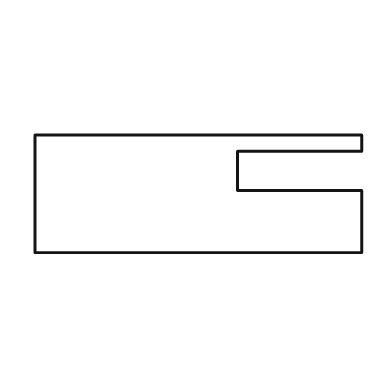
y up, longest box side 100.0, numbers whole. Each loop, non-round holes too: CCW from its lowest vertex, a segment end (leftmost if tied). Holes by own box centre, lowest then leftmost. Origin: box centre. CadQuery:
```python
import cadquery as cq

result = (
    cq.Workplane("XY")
    .moveTo(-50.0, -18.0)
    .lineTo(50.0, -18.0)
    .lineTo(50.0, 1.0)
    .lineTo(12.0, 1.0)
    .lineTo(12.0, 13.0)
    .lineTo(50.0, 13.0)
    .lineTo(50.0, 18.0)
    .lineTo(-50.0, 18.0)
    .close()
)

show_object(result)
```